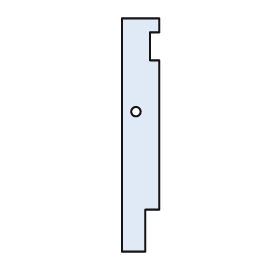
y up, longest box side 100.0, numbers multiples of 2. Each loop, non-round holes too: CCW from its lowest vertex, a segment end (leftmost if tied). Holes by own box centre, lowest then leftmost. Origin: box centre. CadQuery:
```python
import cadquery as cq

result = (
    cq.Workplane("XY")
    .moveTo(-8.0, -50.0)
    .lineTo(2.0, -50.0)
    .lineTo(2.0, -32.0)
    .lineTo(8.0, -32.0)
    .lineTo(8.0, 32.0)
    .lineTo(4.0, 32.0)
    .lineTo(4.0, 44.0)
    .lineTo(8.0, 44.0)
    .lineTo(8.0, 50.0)
    .lineTo(-8.0, 50.0)
    .close()
    .moveTo(-2.0, 10.0)
    .circle(2.0)
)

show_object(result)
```